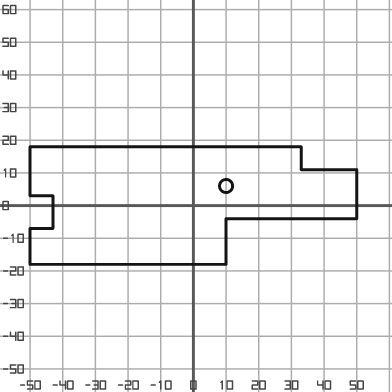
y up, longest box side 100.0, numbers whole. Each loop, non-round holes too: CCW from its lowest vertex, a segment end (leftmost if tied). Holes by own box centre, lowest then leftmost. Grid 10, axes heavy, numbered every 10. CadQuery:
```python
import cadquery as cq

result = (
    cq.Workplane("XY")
    .moveTo(-50.0, -18.0)
    .lineTo(10.0, -18.0)
    .lineTo(10.0, -4.0)
    .lineTo(50.0, -4.0)
    .lineTo(50.0, 11.0)
    .lineTo(33.0, 11.0)
    .lineTo(33.0, 18.0)
    .lineTo(-50.0, 18.0)
    .lineTo(-50.0, 3.0)
    .lineTo(-43.0, 3.0)
    .lineTo(-43.0, -7.0)
    .lineTo(-50.0, -7.0)
    .close()
    .moveTo(10.0, 6.0)
    .circle(2.0)
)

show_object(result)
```